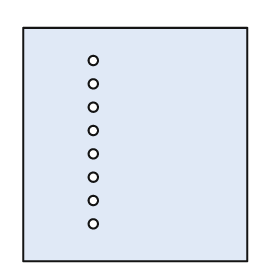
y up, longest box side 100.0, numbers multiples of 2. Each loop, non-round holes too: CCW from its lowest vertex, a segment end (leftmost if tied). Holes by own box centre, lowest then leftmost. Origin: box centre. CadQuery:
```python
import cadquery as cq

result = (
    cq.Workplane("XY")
    .moveTo(-48.0, -50.0)
    .lineTo(48.0, -50.0)
    .lineTo(48.0, 50.0)
    .lineTo(-48.0, 50.0)
    .close()
    .moveTo(-18.0, -34.0)
    .circle(2.0)
    .moveTo(-18.0, -24.0)
    .circle(2.0)
    .moveTo(-18.0, -14.0)
    .circle(2.0)
    .moveTo(-18.0, -4.0)
    .circle(2.0)
    .moveTo(-18.0, 6.0)
    .circle(2.0)
    .moveTo(-18.0, 16.0)
    .circle(2.0)
    .moveTo(-18.0, 26.0)
    .circle(2.0)
    .moveTo(-18.0, 36.0)
    .circle(2.0)
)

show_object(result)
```